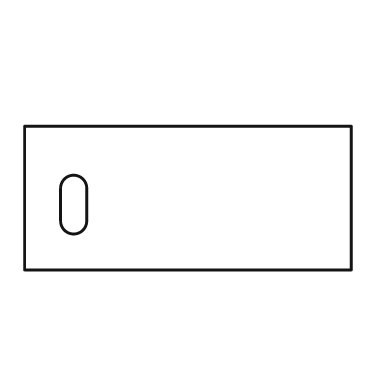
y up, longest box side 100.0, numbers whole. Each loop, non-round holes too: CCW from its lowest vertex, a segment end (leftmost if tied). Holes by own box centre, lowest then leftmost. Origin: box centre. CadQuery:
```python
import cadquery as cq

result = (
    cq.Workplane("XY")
    .moveTo(-50.0, -22.0)
    .lineTo(50.0, -22.0)
    .lineTo(50.0, 22.0)
    .lineTo(-50.0, 22.0)
    .close()
    .moveTo(-39.0, -7.0)
    .threePointArc((-35.0, -11.0), (-31.0, -7.0))
    .lineTo(-31.0, 3.0)
    .threePointArc((-35.0, 7.0), (-39.0, 3.0))
    .close()
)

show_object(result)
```